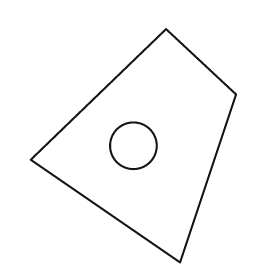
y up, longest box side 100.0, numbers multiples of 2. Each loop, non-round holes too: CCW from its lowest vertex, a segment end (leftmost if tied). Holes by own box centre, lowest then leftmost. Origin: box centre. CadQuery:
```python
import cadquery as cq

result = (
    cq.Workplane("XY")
    .moveTo(20.0, -50.0)
    .lineTo(44.0, 22.0)
    .lineTo(14.0, 50.0)
    .lineTo(-44.0, -6.0)
    .close()
    .moveTo(0.0, 0.0)
    .circle(10.0)
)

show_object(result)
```